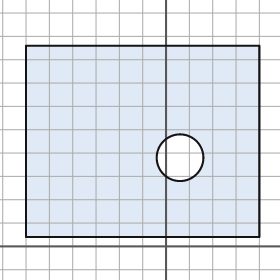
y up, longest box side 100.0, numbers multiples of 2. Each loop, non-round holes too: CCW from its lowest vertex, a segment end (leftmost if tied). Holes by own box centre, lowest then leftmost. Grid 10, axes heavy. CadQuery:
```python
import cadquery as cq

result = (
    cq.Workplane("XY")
    .moveTo(-60.0, 4.0)
    .lineTo(40.0, 4.0)
    .lineTo(40.0, 86.0)
    .lineTo(-60.0, 86.0)
    .close()
    .moveTo(6.0, 38.0)
    .circle(10.0)
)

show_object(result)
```